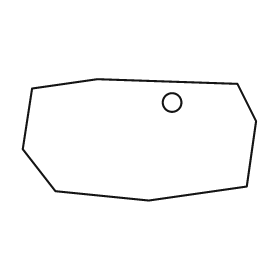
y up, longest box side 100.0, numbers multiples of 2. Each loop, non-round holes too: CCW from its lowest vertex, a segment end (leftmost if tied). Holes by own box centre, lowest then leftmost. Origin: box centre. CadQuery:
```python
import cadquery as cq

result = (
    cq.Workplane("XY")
    .moveTo(4.0, -26.0)
    .lineTo(46.0, -20.0)
    .lineTo(50.0, 8.0)
    .lineTo(42.0, 24.0)
    .lineTo(-18.0, 26.0)
    .lineTo(-46.0, 22.0)
    .lineTo(-50.0, -4.0)
    .lineTo(-36.0, -22.0)
    .close()
    .moveTo(14.0, 16.0)
    .circle(4.0)
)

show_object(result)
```